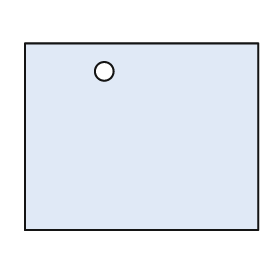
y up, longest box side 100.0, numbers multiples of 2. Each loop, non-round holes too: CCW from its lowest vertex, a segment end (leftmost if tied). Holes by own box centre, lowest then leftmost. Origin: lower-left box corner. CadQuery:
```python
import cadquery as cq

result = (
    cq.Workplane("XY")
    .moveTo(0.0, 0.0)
    .lineTo(100.0, 0.0)
    .lineTo(100.0, 80.0)
    .lineTo(0.0, 80.0)
    .close()
    .moveTo(34.0, 68.0)
    .circle(4.0)
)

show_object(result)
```